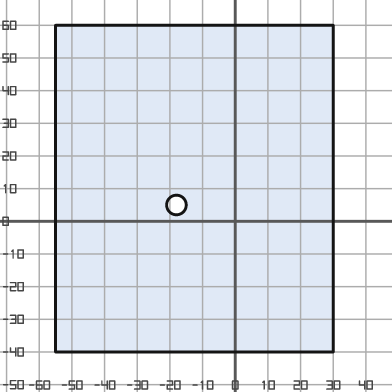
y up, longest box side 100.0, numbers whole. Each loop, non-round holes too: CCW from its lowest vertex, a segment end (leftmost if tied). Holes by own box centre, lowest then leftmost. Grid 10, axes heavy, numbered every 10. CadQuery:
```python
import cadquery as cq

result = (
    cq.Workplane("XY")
    .moveTo(-55.0, -40.0)
    .lineTo(30.0, -40.0)
    .lineTo(30.0, 60.0)
    .lineTo(-55.0, 60.0)
    .close()
    .moveTo(-18.0, 5.0)
    .circle(3.0)
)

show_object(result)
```